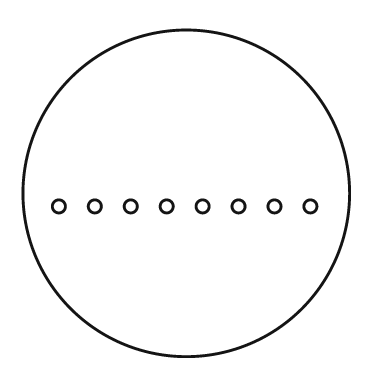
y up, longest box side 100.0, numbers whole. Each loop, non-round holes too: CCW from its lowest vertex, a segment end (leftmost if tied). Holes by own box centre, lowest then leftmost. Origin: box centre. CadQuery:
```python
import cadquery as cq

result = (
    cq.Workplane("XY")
    .moveTo(0.0, 0.0)
    .circle(50.0)
    .moveTo(-39.0, -4.0)
    .circle(2.0)
    .moveTo(-28.0, -4.0)
    .circle(2.0)
    .moveTo(-17.0, -4.0)
    .circle(2.0)
    .moveTo(-6.0, -4.0)
    .circle(2.0)
    .moveTo(5.0, -4.0)
    .circle(2.0)
    .moveTo(16.0, -4.0)
    .circle(2.0)
    .moveTo(27.0, -4.0)
    .circle(2.0)
    .moveTo(38.0, -4.0)
    .circle(2.0)
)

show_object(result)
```